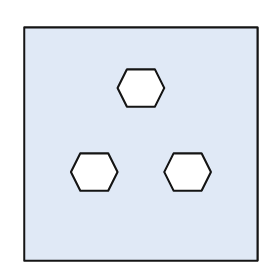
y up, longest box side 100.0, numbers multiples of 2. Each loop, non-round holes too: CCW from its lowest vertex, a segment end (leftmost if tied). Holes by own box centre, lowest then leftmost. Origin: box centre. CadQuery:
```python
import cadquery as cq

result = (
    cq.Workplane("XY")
    .moveTo(-50.0, -50.0)
    .lineTo(50.0, -50.0)
    .lineTo(50.0, 50.0)
    .lineTo(-50.0, 50.0)
    .close()
    .moveTo(-26.0, -20.0)
    .lineTo(-14.0, -20.0)
    .lineTo(-10.0, -12.0)
    .lineTo(-14.0, -4.0)
    .lineTo(-26.0, -4.0)
    .lineTo(-30.0, -12.0)
    .close()
    .moveTo(14.0, -20.0)
    .lineTo(26.0, -20.0)
    .lineTo(30.0, -12.0)
    .lineTo(26.0, -4.0)
    .lineTo(14.0, -4.0)
    .lineTo(10.0, -12.0)
    .close()
    .moveTo(-6.0, 16.0)
    .lineTo(6.0, 16.0)
    .lineTo(10.0, 24.0)
    .lineTo(6.0, 32.0)
    .lineTo(-6.0, 32.0)
    .lineTo(-10.0, 24.0)
    .close()
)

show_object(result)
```